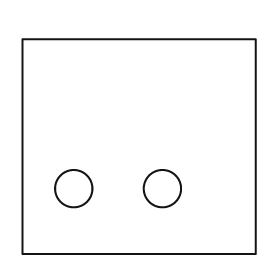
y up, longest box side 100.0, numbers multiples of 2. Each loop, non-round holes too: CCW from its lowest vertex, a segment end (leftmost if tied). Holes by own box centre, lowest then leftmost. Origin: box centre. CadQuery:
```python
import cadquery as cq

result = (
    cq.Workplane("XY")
    .moveTo(-50.0, -46.0)
    .lineTo(50.0, -46.0)
    .lineTo(50.0, 46.0)
    .lineTo(-50.0, 46.0)
    .close()
    .moveTo(-28.0, -18.0)
    .circle(8.0)
    .moveTo(10.0, -18.0)
    .circle(8.0)
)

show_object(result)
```